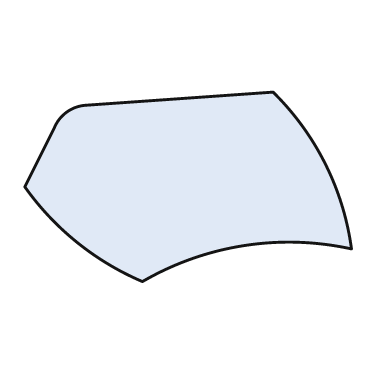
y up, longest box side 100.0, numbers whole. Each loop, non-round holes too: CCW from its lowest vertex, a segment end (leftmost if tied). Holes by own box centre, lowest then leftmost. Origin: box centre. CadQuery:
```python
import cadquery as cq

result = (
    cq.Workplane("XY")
    .moveTo(-14.0, -29.0)
    .threePointArc((17.0, -18.0), (50.0, -19.0))
    .threePointArc((42.0, 7.0), (26.0, 29.0))
    .lineTo(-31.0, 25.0)
    .threePointArc((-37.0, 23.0), (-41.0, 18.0))
    .lineTo(-50.0, 0.0)
    .threePointArc((-34.0, -17.0), (-14.0, -29.0))
    .close()
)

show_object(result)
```